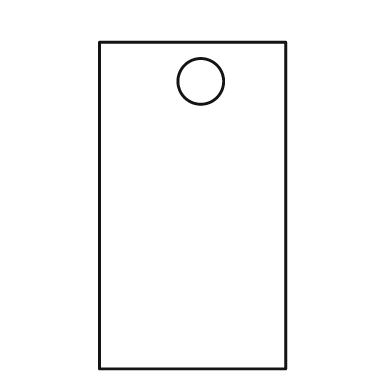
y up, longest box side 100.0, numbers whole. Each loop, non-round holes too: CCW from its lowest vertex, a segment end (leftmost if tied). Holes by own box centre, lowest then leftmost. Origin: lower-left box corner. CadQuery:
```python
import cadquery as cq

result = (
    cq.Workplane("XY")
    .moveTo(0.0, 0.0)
    .lineTo(57.0, 0.0)
    .lineTo(57.0, 100.0)
    .lineTo(0.0, 100.0)
    .close()
    .moveTo(31.0, 88.0)
    .circle(7.0)
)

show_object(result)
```